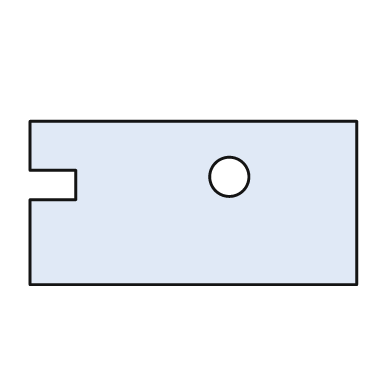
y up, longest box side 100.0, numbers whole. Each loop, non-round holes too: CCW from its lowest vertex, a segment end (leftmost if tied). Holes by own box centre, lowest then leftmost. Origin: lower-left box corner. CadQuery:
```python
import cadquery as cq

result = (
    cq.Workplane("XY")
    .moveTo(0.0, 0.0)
    .lineTo(100.0, 0.0)
    .lineTo(100.0, 50.0)
    .lineTo(0.0, 50.0)
    .lineTo(0.0, 35.0)
    .lineTo(14.0, 35.0)
    .lineTo(14.0, 26.0)
    .lineTo(0.0, 26.0)
    .close()
    .moveTo(61.0, 33.0)
    .circle(6.0)
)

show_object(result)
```